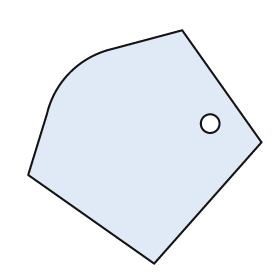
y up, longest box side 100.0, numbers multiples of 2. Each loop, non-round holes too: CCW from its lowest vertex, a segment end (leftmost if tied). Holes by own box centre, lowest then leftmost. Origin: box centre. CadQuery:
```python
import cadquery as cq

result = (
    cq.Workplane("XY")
    .moveTo(4.0, -50.0)
    .lineTo(50.0, 2.0)
    .lineTo(16.0, 50.0)
    .lineTo(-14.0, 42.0)
    .threePointArc((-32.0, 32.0), (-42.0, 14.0))
    .lineTo(-50.0, -12.0)
    .close()
    .moveTo(28.0, 10.0)
    .circle(4.0)
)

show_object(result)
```